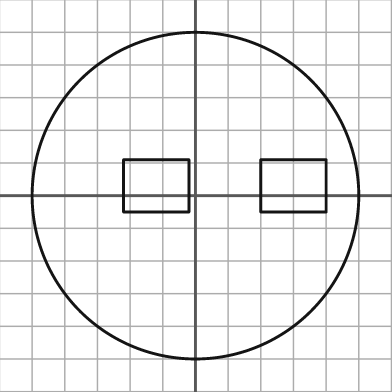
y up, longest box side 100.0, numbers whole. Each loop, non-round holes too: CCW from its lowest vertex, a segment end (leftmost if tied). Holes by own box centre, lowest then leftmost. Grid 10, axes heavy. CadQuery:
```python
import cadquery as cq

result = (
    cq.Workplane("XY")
    .moveTo(0.0, 0.0)
    .circle(50.0)
    .moveTo(-22.0, -5.0)
    .lineTo(-2.0, -5.0)
    .lineTo(-2.0, 11.0)
    .lineTo(-22.0, 11.0)
    .close()
    .moveTo(20.0, -5.0)
    .lineTo(40.0, -5.0)
    .lineTo(40.0, 11.0)
    .lineTo(20.0, 11.0)
    .close()
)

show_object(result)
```